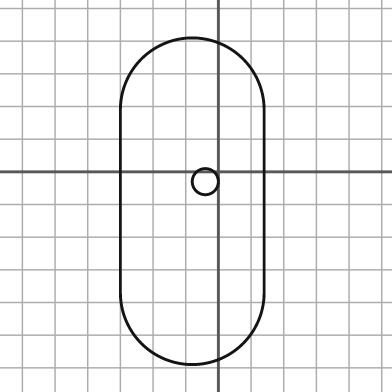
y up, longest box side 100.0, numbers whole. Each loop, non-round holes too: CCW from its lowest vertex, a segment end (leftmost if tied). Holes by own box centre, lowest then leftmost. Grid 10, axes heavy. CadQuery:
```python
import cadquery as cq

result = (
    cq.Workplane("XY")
    .moveTo(-30.0, -37.0)
    .threePointArc((-8.0, -59.0), (14.0, -37.0))
    .lineTo(14.0, 19.0)
    .threePointArc((-8.0, 41.0), (-30.0, 19.0))
    .close()
    .moveTo(-4.0, -3.0)
    .circle(4.0)
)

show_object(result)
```